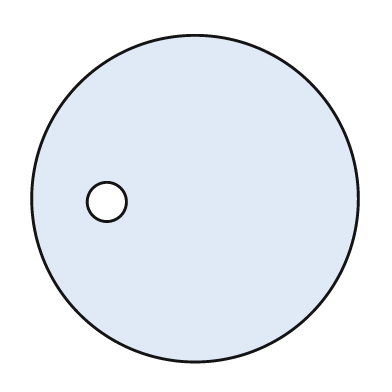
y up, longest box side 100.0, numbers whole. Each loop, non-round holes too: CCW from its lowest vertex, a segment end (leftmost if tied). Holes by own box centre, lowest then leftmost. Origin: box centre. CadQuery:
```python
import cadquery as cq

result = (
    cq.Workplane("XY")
    .moveTo(0.0, 0.0)
    .circle(50.0)
    .moveTo(-27.0, -1.0)
    .circle(6.0)
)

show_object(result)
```